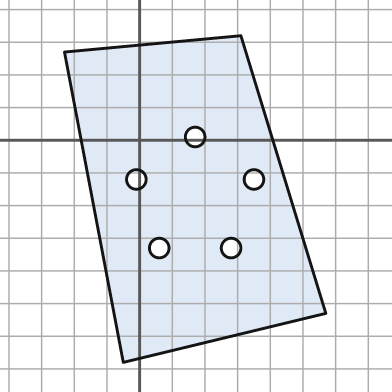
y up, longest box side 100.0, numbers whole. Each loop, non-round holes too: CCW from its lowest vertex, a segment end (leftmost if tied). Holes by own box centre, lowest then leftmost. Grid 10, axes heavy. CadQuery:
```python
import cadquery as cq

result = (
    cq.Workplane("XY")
    .moveTo(-5.0, -68.0)
    .lineTo(57.0, -53.0)
    .lineTo(31.0, 32.0)
    .lineTo(-23.0, 27.0)
    .close()
    .moveTo(6.0, -33.0)
    .circle(3.0)
    .moveTo(28.0, -33.0)
    .circle(3.0)
    .moveTo(-1.0, -12.0)
    .circle(3.0)
    .moveTo(35.0, -12.0)
    .circle(3.0)
    .moveTo(17.0, 1.0)
    .circle(3.0)
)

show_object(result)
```